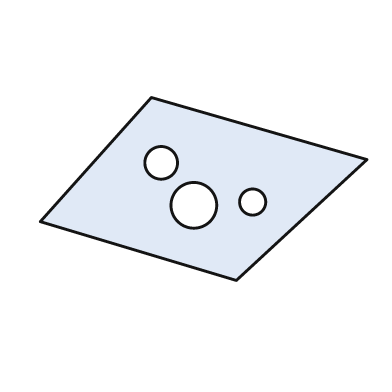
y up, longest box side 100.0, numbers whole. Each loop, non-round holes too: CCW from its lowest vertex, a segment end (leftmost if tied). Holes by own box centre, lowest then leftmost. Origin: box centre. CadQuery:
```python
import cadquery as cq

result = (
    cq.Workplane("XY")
    .moveTo(10.0, -28.0)
    .lineTo(50.0, 9.0)
    .lineTo(-16.0, 28.0)
    .lineTo(-50.0, -10.0)
    .close()
    .moveTo(-3.0, -5.0)
    .circle(7.0)
    .moveTo(15.0, -4.0)
    .circle(4.0)
    .moveTo(-13.0, 8.0)
    .circle(5.0)
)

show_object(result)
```